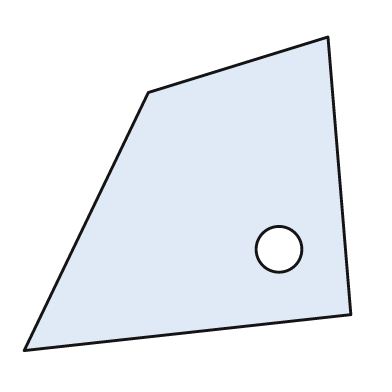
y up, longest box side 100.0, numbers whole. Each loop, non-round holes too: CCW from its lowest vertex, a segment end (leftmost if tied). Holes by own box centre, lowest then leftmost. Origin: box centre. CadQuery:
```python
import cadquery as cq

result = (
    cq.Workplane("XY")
    .moveTo(-50.0, -48.0)
    .lineTo(50.0, -37.0)
    .lineTo(43.0, 48.0)
    .lineTo(-12.0, 31.0)
    .close()
    .moveTo(28.0, -17.0)
    .circle(7.0)
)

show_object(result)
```